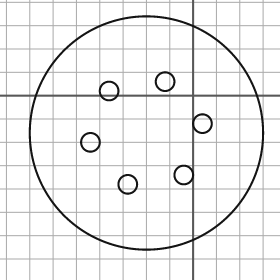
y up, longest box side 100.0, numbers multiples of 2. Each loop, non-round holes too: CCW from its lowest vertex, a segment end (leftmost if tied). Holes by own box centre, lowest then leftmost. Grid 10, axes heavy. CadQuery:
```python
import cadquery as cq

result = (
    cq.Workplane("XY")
    .moveTo(-20.0, -16.0)
    .circle(50.0)
    .moveTo(-28.0, -38.0)
    .circle(4.0)
    .moveTo(-4.0, -34.0)
    .circle(4.0)
    .moveTo(-44.0, -20.0)
    .circle(4.0)
    .moveTo(4.0, -12.0)
    .circle(4.0)
    .moveTo(-36.0, 2.0)
    .circle(4.0)
    .moveTo(-12.0, 6.0)
    .circle(4.0)
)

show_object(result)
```